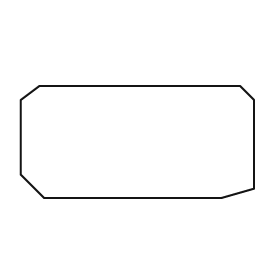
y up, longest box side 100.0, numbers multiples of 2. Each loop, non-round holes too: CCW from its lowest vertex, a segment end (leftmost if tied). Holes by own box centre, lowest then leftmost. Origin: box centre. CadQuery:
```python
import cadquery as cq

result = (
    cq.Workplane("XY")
    .moveTo(-40.0, -24.0)
    .lineTo(36.0, -24.0)
    .lineTo(50.0, -20.0)
    .lineTo(50.0, 18.0)
    .lineTo(44.0, 24.0)
    .lineTo(-42.0, 24.0)
    .lineTo(-50.0, 18.0)
    .lineTo(-50.0, -14.0)
    .close()
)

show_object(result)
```